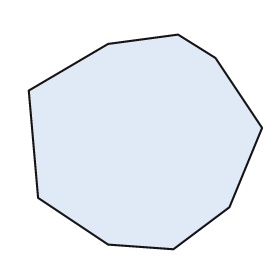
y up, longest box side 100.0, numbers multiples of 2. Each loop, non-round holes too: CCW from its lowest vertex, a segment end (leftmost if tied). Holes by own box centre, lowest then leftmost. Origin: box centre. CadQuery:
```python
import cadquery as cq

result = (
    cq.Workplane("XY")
    .moveTo(12.0, -46.0)
    .lineTo(36.0, -28.0)
    .lineTo(50.0, 6.0)
    .lineTo(30.0, 36.0)
    .lineTo(14.0, 46.0)
    .lineTo(-16.0, 42.0)
    .lineTo(-50.0, 22.0)
    .lineTo(-46.0, -24.0)
    .lineTo(-16.0, -44.0)
    .close()
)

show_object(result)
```